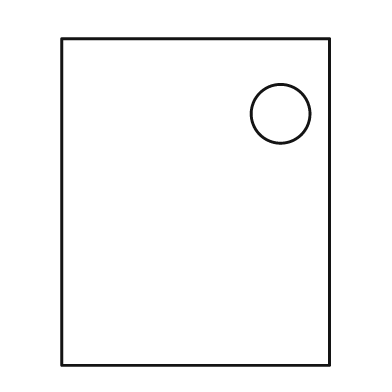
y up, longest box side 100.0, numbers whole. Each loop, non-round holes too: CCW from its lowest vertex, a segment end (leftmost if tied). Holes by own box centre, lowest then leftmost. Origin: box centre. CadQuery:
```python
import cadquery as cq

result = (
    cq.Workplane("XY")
    .moveTo(-41.0, -50.0)
    .lineTo(41.0, -50.0)
    .lineTo(41.0, 50.0)
    .lineTo(-41.0, 50.0)
    .close()
    .moveTo(26.0, 27.0)
    .circle(9.0)
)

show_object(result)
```